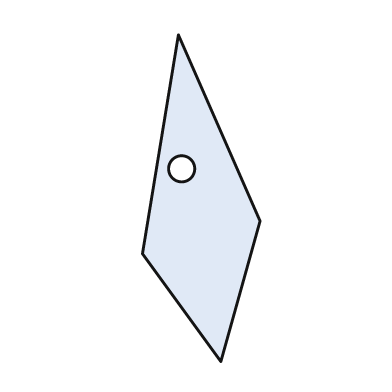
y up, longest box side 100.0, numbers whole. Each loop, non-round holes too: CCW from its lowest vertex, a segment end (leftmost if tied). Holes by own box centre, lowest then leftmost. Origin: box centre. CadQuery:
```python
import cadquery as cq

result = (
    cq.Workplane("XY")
    .moveTo(6.0, -50.0)
    .lineTo(18.0, -7.0)
    .lineTo(-7.0, 50.0)
    .lineTo(-18.0, -17.0)
    .close()
    .moveTo(-6.0, 9.0)
    .circle(4.0)
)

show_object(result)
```